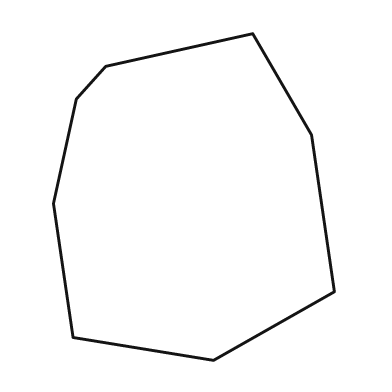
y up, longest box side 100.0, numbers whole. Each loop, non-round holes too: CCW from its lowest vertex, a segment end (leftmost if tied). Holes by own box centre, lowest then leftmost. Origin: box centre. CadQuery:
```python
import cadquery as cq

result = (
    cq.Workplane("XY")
    .moveTo(6.0, -50.0)
    .lineTo(43.0, -29.0)
    .lineTo(36.0, 19.0)
    .lineTo(18.0, 50.0)
    .lineTo(-27.0, 40.0)
    .lineTo(-36.0, 30.0)
    .lineTo(-43.0, -2.0)
    .lineTo(-37.0, -43.0)
    .close()
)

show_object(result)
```